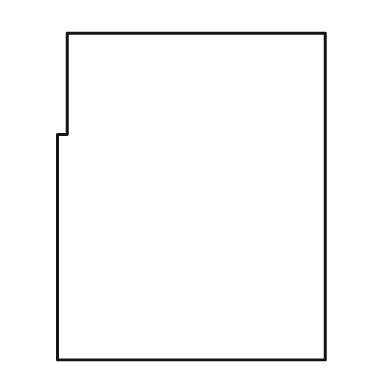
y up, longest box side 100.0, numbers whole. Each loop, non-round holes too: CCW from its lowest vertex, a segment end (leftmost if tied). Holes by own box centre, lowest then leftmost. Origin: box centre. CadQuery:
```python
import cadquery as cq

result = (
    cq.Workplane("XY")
    .moveTo(-41.0, -50.0)
    .lineTo(41.0, -50.0)
    .lineTo(41.0, 50.0)
    .lineTo(-38.0, 50.0)
    .lineTo(-38.0, 19.0)
    .lineTo(-41.0, 19.0)
    .close()
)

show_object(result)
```